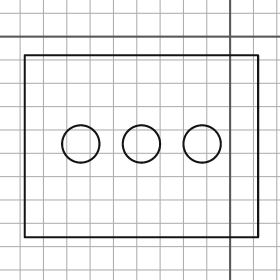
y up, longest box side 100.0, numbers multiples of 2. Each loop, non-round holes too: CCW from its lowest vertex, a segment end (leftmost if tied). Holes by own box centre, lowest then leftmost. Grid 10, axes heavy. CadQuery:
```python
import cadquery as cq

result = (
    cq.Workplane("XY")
    .moveTo(-88.0, -86.0)
    .lineTo(12.0, -86.0)
    .lineTo(12.0, -8.0)
    .lineTo(-88.0, -8.0)
    .close()
    .moveTo(-64.0, -46.0)
    .circle(8.0)
    .moveTo(-38.0, -46.0)
    .circle(8.0)
    .moveTo(-12.0, -46.0)
    .circle(8.0)
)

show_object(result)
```